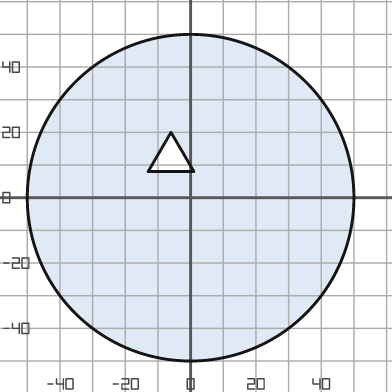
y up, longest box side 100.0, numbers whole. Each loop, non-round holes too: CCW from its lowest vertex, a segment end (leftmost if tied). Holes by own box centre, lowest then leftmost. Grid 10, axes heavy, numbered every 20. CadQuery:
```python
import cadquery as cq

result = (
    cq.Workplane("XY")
    .moveTo(0.0, 0.0)
    .circle(50.0)
    .moveTo(-13.0, 8.0)
    .lineTo(1.0, 8.0)
    .lineTo(-6.0, 20.0)
    .close()
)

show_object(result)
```